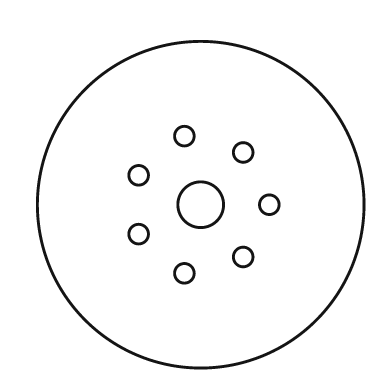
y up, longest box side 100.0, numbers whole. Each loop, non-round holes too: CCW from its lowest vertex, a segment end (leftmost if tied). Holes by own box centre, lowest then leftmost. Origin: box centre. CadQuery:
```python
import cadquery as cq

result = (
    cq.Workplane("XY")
    .moveTo(0.0, 0.0)
    .circle(50.0)
    .moveTo(-5.0, -21.0)
    .circle(3.0)
    .moveTo(13.0, -16.0)
    .circle(3.0)
    .moveTo(-19.0, -9.0)
    .circle(3.0)
    .moveTo(0.0, 0.0)
    .circle(7.0)
    .moveTo(21.0, 0.0)
    .circle(3.0)
    .moveTo(-19.0, 9.0)
    .circle(3.0)
    .moveTo(13.0, 16.0)
    .circle(3.0)
    .moveTo(-5.0, 21.0)
    .circle(3.0)
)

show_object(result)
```